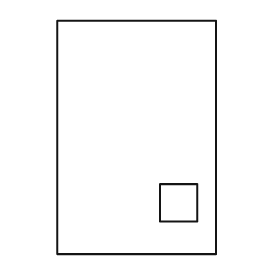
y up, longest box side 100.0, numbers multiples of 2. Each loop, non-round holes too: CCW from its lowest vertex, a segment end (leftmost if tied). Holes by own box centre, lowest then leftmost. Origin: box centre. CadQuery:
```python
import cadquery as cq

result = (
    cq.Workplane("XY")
    .moveTo(-34.0, -50.0)
    .lineTo(34.0, -50.0)
    .lineTo(34.0, 50.0)
    .lineTo(-34.0, 50.0)
    .close()
    .moveTo(10.0, -36.0)
    .lineTo(26.0, -36.0)
    .lineTo(26.0, -20.0)
    .lineTo(10.0, -20.0)
    .close()
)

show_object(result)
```